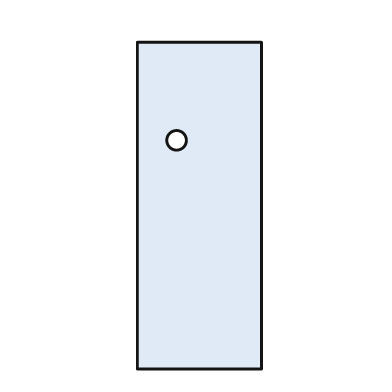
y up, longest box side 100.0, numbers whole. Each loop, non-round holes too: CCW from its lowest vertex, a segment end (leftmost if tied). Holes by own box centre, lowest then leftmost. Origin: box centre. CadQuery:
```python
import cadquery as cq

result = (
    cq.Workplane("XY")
    .moveTo(-19.0, -50.0)
    .lineTo(19.0, -50.0)
    .lineTo(19.0, 50.0)
    .lineTo(-19.0, 50.0)
    .close()
    .moveTo(-7.0, 20.0)
    .circle(3.0)
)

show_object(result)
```